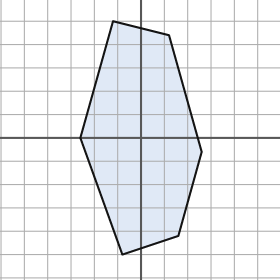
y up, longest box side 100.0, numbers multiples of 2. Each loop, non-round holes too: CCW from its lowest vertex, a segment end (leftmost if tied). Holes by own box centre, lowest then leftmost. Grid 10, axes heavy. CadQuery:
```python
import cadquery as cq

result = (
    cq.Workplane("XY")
    .moveTo(-8.0, -50.0)
    .lineTo(16.0, -42.0)
    .lineTo(26.0, -6.0)
    .lineTo(12.0, 44.0)
    .lineTo(-12.0, 50.0)
    .lineTo(-26.0, 0.0)
    .close()
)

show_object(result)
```